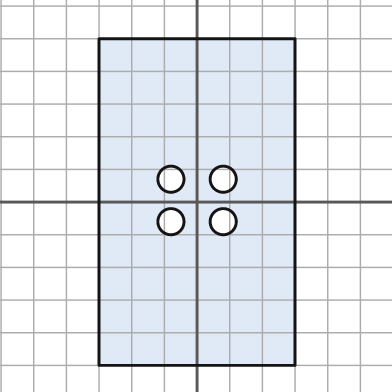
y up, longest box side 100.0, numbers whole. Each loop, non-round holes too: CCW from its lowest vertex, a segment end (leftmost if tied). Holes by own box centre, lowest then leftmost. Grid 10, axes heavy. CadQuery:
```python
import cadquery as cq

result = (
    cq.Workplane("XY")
    .moveTo(-30.0, -50.0)
    .lineTo(30.0, -50.0)
    .lineTo(30.0, 50.0)
    .lineTo(-30.0, 50.0)
    .close()
    .moveTo(-8.0, -6.0)
    .circle(4.0)
    .moveTo(8.0, -6.0)
    .circle(4.0)
    .moveTo(-8.0, 7.0)
    .circle(4.0)
    .moveTo(8.0, 7.0)
    .circle(4.0)
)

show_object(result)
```